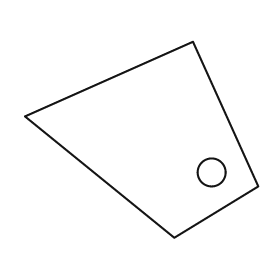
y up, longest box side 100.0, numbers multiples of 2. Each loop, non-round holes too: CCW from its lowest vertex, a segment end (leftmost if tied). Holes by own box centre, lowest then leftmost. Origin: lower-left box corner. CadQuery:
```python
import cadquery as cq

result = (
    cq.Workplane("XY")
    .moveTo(64.0, 0.0)
    .lineTo(100.0, 22.0)
    .lineTo(72.0, 84.0)
    .lineTo(0.0, 52.0)
    .close()
    .moveTo(80.0, 28.0)
    .circle(6.0)
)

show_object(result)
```